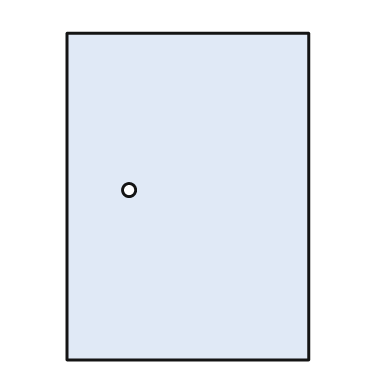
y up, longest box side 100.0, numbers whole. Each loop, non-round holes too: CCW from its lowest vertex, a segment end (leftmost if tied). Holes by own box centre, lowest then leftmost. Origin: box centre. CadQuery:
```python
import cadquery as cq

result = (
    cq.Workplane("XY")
    .moveTo(-37.0, -50.0)
    .lineTo(37.0, -50.0)
    .lineTo(37.0, 50.0)
    .lineTo(-37.0, 50.0)
    .close()
    .moveTo(-18.0, 2.0)
    .circle(2.0)
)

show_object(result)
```